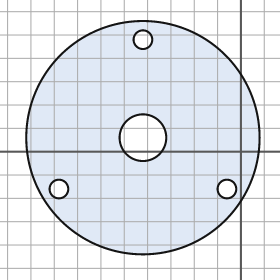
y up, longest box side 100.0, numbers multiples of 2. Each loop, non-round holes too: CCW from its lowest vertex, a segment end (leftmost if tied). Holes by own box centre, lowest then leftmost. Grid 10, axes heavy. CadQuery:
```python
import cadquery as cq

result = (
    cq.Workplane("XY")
    .moveTo(-42.0, 6.0)
    .circle(50.0)
    .moveTo(-78.0, -16.0)
    .circle(4.0)
    .moveTo(-6.0, -16.0)
    .circle(4.0)
    .moveTo(-42.0, 6.0)
    .circle(10.0)
    .moveTo(-42.0, 48.0)
    .circle(4.0)
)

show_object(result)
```